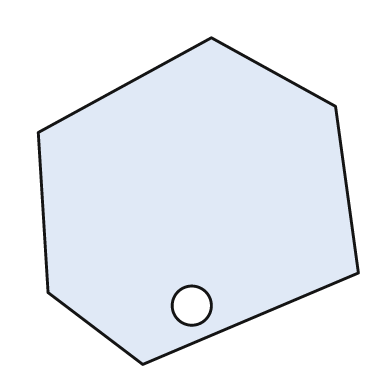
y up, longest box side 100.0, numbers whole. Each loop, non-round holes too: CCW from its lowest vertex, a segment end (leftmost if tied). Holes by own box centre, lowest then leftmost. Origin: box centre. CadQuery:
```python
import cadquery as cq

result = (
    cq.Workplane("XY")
    .moveTo(-17.0, -50.0)
    .lineTo(49.0, -22.0)
    .lineTo(42.0, 29.0)
    .lineTo(4.0, 50.0)
    .lineTo(-49.0, 21.0)
    .lineTo(-46.0, -28.0)
    .close()
    .moveTo(-2.0, -32.0)
    .circle(6.0)
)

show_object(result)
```